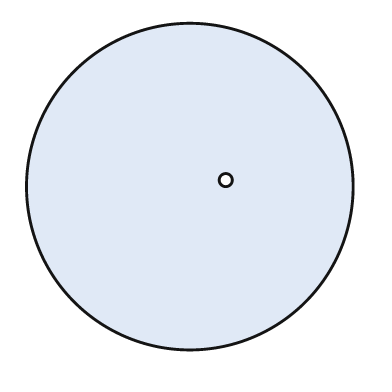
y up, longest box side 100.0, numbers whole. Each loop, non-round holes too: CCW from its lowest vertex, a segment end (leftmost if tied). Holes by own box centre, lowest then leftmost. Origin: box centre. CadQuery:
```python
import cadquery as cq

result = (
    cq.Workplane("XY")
    .moveTo(0.0, 0.0)
    .circle(50.0)
    .moveTo(11.0, 2.0)
    .circle(2.0)
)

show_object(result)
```